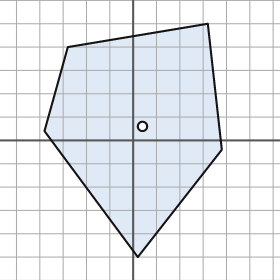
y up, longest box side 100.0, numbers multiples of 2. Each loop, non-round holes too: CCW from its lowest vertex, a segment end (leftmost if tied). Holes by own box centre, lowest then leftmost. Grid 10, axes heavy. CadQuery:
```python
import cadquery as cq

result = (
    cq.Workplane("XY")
    .moveTo(2.0, -50.0)
    .lineTo(38.0, -4.0)
    .lineTo(32.0, 50.0)
    .lineTo(-28.0, 40.0)
    .lineTo(-38.0, 4.0)
    .close()
    .moveTo(4.0, 6.0)
    .circle(2.0)
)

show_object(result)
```